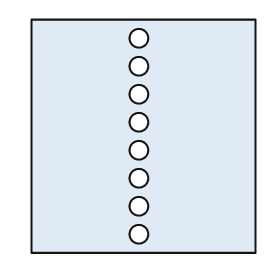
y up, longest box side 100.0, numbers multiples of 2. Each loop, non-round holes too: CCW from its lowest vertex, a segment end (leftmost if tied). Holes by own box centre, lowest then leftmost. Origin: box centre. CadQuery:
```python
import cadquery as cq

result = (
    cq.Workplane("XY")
    .moveTo(-48.0, -50.0)
    .lineTo(48.0, -50.0)
    .lineTo(48.0, 50.0)
    .lineTo(-48.0, 50.0)
    .close()
    .moveTo(-2.0, -42.0)
    .circle(4.0)
    .moveTo(-2.0, -30.0)
    .circle(4.0)
    .moveTo(-2.0, -18.0)
    .circle(4.0)
    .moveTo(-2.0, -6.0)
    .circle(4.0)
    .moveTo(-2.0, 6.0)
    .circle(4.0)
    .moveTo(-2.0, 18.0)
    .circle(4.0)
    .moveTo(-2.0, 30.0)
    .circle(4.0)
    .moveTo(-2.0, 42.0)
    .circle(4.0)
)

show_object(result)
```